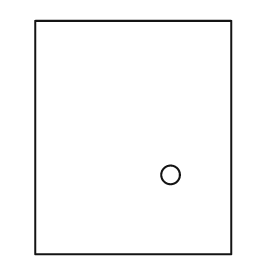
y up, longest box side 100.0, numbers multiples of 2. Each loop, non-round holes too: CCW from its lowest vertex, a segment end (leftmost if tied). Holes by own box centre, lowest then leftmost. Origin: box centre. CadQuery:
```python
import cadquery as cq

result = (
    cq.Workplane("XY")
    .moveTo(-42.0, -50.0)
    .lineTo(42.0, -50.0)
    .lineTo(42.0, 50.0)
    .lineTo(-42.0, 50.0)
    .close()
    .moveTo(16.0, -16.0)
    .circle(4.0)
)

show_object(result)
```